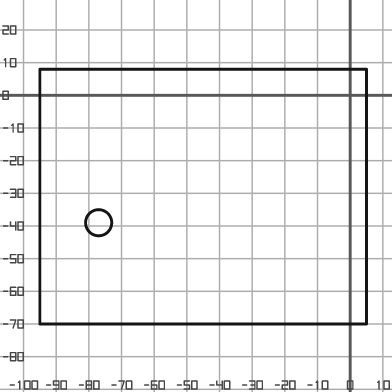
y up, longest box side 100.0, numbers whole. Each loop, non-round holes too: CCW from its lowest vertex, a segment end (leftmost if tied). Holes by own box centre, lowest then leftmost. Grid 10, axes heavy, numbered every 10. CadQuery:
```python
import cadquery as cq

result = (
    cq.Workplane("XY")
    .moveTo(-95.0, -70.0)
    .lineTo(5.0, -70.0)
    .lineTo(5.0, 8.0)
    .lineTo(-95.0, 8.0)
    .close()
    .moveTo(-77.0, -39.0)
    .circle(4.0)
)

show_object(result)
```